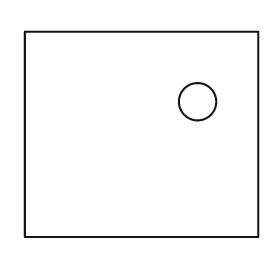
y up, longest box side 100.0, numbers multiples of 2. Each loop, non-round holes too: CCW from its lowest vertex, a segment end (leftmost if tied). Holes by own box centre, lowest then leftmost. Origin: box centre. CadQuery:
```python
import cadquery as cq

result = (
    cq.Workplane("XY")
    .moveTo(-50.0, -44.0)
    .lineTo(50.0, -44.0)
    .lineTo(50.0, 44.0)
    .lineTo(-50.0, 44.0)
    .close()
    .moveTo(24.0, 14.0)
    .circle(8.0)
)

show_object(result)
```